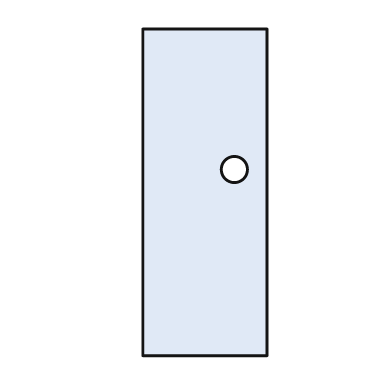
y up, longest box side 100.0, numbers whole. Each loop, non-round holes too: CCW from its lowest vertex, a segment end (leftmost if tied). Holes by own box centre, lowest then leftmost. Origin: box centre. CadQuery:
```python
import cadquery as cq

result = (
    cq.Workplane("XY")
    .moveTo(-19.0, -50.0)
    .lineTo(19.0, -50.0)
    .lineTo(19.0, 50.0)
    .lineTo(-19.0, 50.0)
    .close()
    .moveTo(9.0, 7.0)
    .circle(4.0)
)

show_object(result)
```